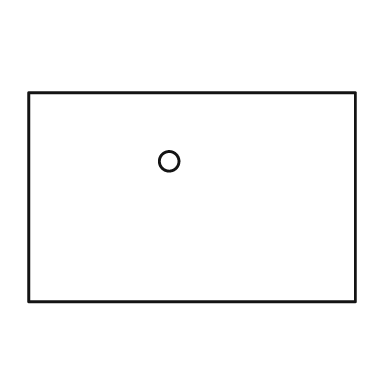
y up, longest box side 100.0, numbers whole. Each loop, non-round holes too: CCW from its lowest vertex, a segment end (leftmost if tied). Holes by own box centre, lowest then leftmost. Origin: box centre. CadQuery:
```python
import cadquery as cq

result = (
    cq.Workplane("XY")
    .moveTo(-50.0, -32.0)
    .lineTo(50.0, -32.0)
    .lineTo(50.0, 32.0)
    .lineTo(-50.0, 32.0)
    .close()
    .moveTo(-7.0, 11.0)
    .circle(3.0)
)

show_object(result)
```